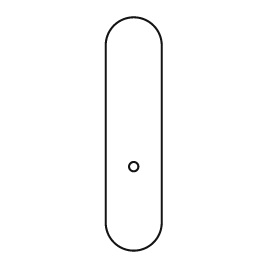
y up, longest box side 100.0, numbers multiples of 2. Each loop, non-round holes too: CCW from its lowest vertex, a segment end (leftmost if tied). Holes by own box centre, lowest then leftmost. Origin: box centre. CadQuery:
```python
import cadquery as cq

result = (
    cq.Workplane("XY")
    .moveTo(-12.0, -38.0)
    .threePointArc((0.0, -50.0), (12.0, -38.0))
    .lineTo(12.0, 38.0)
    .threePointArc((0.0, 50.0), (-12.0, 38.0))
    .close()
    .moveTo(0.0, -14.0)
    .circle(2.0)
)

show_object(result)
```